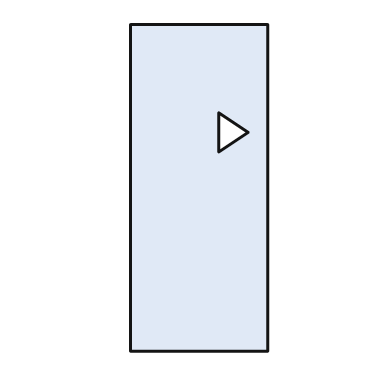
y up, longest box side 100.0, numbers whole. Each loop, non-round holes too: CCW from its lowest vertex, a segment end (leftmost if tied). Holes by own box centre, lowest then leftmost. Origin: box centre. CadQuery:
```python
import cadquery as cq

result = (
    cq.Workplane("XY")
    .moveTo(-21.0, -50.0)
    .lineTo(21.0, -50.0)
    .lineTo(21.0, 50.0)
    .lineTo(-21.0, 50.0)
    .close()
    .moveTo(6.0, 11.0)
    .lineTo(15.0, 17.0)
    .lineTo(6.0, 23.0)
    .close()
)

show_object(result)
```